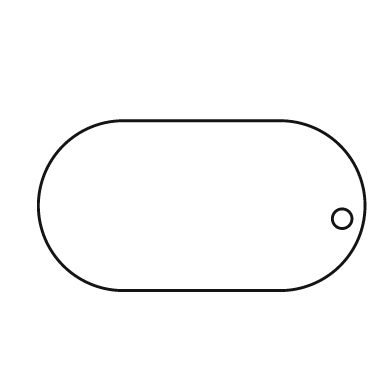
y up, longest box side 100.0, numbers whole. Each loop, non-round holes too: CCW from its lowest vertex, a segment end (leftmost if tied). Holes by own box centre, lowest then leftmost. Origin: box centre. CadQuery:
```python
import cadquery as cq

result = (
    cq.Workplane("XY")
    .moveTo(-24.0, -26.0)
    .lineTo(24.0, -26.0)
    .threePointArc((50.0, 0.0), (24.0, 26.0))
    .lineTo(-24.0, 26.0)
    .threePointArc((-50.0, 0.0), (-24.0, -26.0))
    .close()
    .moveTo(43.0, -4.0)
    .circle(3.0)
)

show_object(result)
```